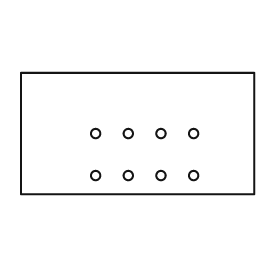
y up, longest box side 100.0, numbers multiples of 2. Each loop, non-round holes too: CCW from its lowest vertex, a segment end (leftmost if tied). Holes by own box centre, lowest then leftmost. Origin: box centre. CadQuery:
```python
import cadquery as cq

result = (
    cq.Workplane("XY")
    .moveTo(-50.0, -26.0)
    .lineTo(50.0, -26.0)
    .lineTo(50.0, 26.0)
    .lineTo(-50.0, 26.0)
    .close()
    .moveTo(-18.0, -18.0)
    .circle(2.0)
    .moveTo(-4.0, -18.0)
    .circle(2.0)
    .moveTo(10.0, -18.0)
    .circle(2.0)
    .moveTo(24.0, -18.0)
    .circle(2.0)
    .moveTo(-18.0, 0.0)
    .circle(2.0)
    .moveTo(-4.0, 0.0)
    .circle(2.0)
    .moveTo(10.0, 0.0)
    .circle(2.0)
    .moveTo(24.0, 0.0)
    .circle(2.0)
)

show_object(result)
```